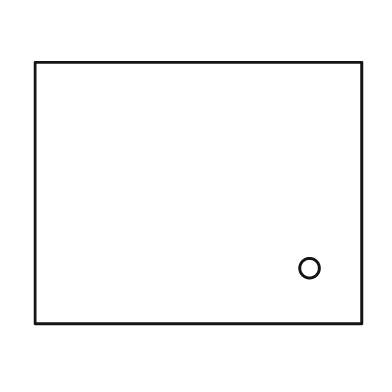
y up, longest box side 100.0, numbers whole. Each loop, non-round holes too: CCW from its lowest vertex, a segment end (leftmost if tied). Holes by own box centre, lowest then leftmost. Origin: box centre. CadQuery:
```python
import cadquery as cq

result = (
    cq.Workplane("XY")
    .moveTo(-50.0, -40.0)
    .lineTo(50.0, -40.0)
    .lineTo(50.0, 40.0)
    .lineTo(-50.0, 40.0)
    .close()
    .moveTo(34.0, -23.0)
    .circle(3.0)
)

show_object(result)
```